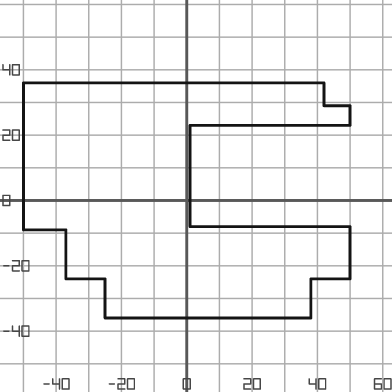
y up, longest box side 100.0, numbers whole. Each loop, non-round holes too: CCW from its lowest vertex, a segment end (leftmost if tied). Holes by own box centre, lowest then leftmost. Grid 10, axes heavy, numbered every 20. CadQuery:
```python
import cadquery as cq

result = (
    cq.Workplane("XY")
    .moveTo(-25.0, -36.0)
    .lineTo(38.0, -36.0)
    .lineTo(38.0, -24.0)
    .lineTo(50.0, -24.0)
    .lineTo(50.0, -8.0)
    .lineTo(1.0, -8.0)
    .lineTo(1.0, 23.0)
    .lineTo(50.0, 23.0)
    .lineTo(50.0, 29.0)
    .lineTo(42.0, 29.0)
    .lineTo(42.0, 36.0)
    .lineTo(-50.0, 36.0)
    .lineTo(-50.0, -9.0)
    .lineTo(-37.0, -9.0)
    .lineTo(-37.0, -24.0)
    .lineTo(-25.0, -24.0)
    .close()
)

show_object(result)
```